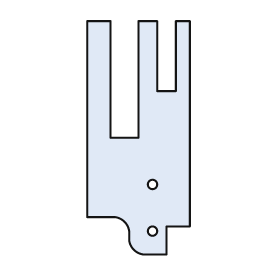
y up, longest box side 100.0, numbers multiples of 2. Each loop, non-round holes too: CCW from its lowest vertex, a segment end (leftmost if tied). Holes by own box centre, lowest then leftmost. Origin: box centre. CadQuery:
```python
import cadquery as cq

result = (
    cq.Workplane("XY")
    .moveTo(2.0, -50.0)
    .lineTo(12.0, -50.0)
    .lineTo(12.0, -38.0)
    .lineTo(22.0, -38.0)
    .lineTo(22.0, 50.0)
    .lineTo(16.0, 50.0)
    .lineTo(16.0, 20.0)
    .lineTo(8.0, 20.0)
    .lineTo(8.0, 50.0)
    .lineTo(0.0, 50.0)
    .lineTo(0.0, 0.0)
    .lineTo(-12.0, 0.0)
    .lineTo(-12.0, 50.0)
    .lineTo(-22.0, 50.0)
    .lineTo(-22.0, -34.0)
    .lineTo(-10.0, -34.0)
    .threePointArc((-6.0, -36.0), (-4.0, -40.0))
    .lineTo(-4.0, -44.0)
    .threePointArc((-2.0, -48.0), (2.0, -50.0))
    .close()
    .moveTo(6.0, -40.0)
    .circle(2.0)
    .moveTo(6.0, -20.0)
    .circle(2.0)
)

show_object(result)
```